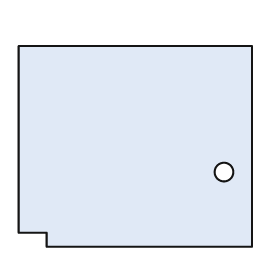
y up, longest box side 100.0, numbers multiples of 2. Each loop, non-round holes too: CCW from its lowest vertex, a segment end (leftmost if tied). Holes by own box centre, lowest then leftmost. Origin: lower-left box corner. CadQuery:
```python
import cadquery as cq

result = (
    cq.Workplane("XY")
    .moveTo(12.0, 0.0)
    .lineTo(100.0, 0.0)
    .lineTo(100.0, 86.0)
    .lineTo(0.0, 86.0)
    .lineTo(0.0, 6.0)
    .lineTo(12.0, 6.0)
    .close()
    .moveTo(88.0, 32.0)
    .circle(4.0)
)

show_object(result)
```